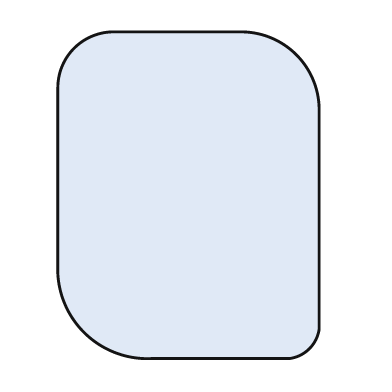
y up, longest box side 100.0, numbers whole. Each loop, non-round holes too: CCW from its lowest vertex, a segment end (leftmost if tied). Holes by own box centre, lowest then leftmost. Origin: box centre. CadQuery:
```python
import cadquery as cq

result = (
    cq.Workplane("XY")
    .moveTo(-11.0, -50.0)
    .lineTo(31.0, -50.0)
    .threePointArc((37.0, -47.0), (40.0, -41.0))
    .lineTo(40.0, 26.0)
    .threePointArc((33.0, 43.0), (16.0, 50.0))
    .lineTo(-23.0, 50.0)
    .threePointArc((-35.0, 45.0), (-40.0, 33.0))
    .lineTo(-40.0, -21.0)
    .threePointArc((-32.0, -42.0), (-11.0, -50.0))
    .close()
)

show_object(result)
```